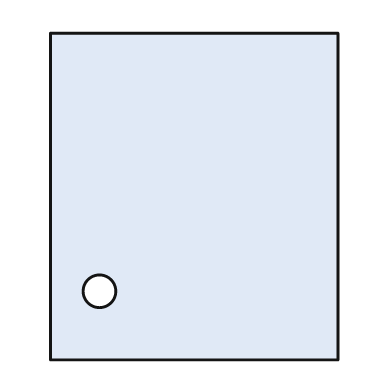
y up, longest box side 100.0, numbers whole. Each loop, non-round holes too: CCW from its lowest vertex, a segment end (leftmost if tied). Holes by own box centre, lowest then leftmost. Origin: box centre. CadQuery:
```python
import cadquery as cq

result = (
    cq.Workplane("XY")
    .moveTo(-44.0, -50.0)
    .lineTo(44.0, -50.0)
    .lineTo(44.0, 50.0)
    .lineTo(-44.0, 50.0)
    .close()
    .moveTo(-29.0, -29.0)
    .circle(5.0)
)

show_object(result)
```